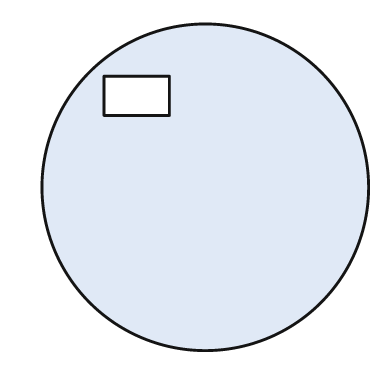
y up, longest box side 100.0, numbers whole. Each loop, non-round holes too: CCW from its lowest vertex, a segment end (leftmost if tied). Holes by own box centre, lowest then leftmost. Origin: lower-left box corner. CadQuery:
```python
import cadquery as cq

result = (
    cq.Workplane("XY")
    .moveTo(50.0, 50.0)
    .circle(50.0)
    .moveTo(19.0, 72.0)
    .lineTo(39.0, 72.0)
    .lineTo(39.0, 84.0)
    .lineTo(19.0, 84.0)
    .close()
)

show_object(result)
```